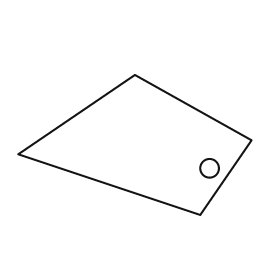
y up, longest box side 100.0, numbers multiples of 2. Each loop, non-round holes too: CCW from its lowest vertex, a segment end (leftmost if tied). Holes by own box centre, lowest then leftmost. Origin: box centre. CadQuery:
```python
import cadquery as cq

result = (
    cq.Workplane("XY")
    .moveTo(28.0, -30.0)
    .lineTo(50.0, 2.0)
    .lineTo(0.0, 30.0)
    .lineTo(-50.0, -4.0)
    .close()
    .moveTo(32.0, -10.0)
    .circle(4.0)
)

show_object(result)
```